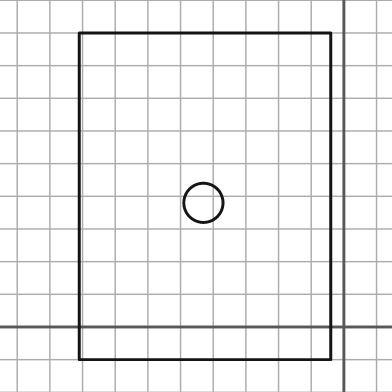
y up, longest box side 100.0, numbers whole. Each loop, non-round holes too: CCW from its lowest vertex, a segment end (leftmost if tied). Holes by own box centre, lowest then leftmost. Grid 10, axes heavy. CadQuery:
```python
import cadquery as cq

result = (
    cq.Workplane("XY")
    .moveTo(-81.0, -10.0)
    .lineTo(-4.0, -10.0)
    .lineTo(-4.0, 90.0)
    .lineTo(-81.0, 90.0)
    .close()
    .moveTo(-43.0, 38.0)
    .circle(6.0)
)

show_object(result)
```